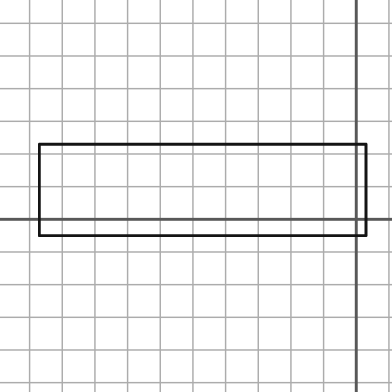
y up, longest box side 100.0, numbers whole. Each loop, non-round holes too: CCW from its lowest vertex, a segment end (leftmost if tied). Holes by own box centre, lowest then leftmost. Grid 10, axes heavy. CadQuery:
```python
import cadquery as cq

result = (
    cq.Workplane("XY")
    .moveTo(-97.0, -5.0)
    .lineTo(3.0, -5.0)
    .lineTo(3.0, 23.0)
    .lineTo(-97.0, 23.0)
    .close()
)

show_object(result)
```